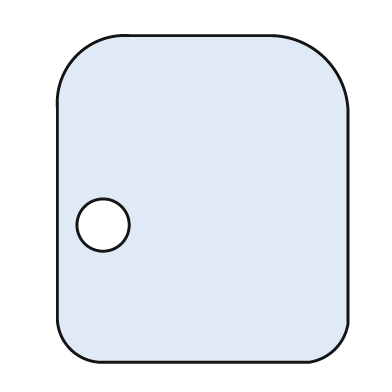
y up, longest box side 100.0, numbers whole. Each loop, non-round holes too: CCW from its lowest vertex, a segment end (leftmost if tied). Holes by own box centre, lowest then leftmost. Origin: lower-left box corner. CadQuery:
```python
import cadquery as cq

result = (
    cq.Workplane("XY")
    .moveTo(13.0, 0.0)
    .lineTo(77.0, 0.0)
    .threePointArc((85.0, 4.0), (89.0, 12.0))
    .lineTo(89.0, 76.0)
    .threePointArc((82.0, 93.0), (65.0, 100.0))
    .lineTo(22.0, 100.0)
    .threePointArc((6.0, 94.0), (0.0, 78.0))
    .lineTo(0.0, 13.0)
    .threePointArc((4.0, 4.0), (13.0, 0.0))
    .close()
    .moveTo(14.0, 42.0)
    .circle(8.0)
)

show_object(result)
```